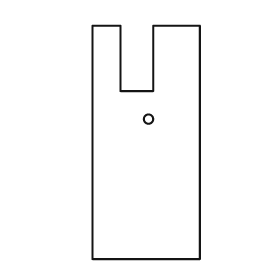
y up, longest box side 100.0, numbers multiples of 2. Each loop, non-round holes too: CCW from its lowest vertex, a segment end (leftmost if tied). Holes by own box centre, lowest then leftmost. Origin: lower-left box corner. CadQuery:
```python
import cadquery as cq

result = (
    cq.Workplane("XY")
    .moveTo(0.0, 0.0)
    .lineTo(46.0, 0.0)
    .lineTo(46.0, 100.0)
    .lineTo(26.0, 100.0)
    .lineTo(26.0, 72.0)
    .lineTo(12.0, 72.0)
    .lineTo(12.0, 100.0)
    .lineTo(0.0, 100.0)
    .close()
    .moveTo(24.0, 60.0)
    .circle(2.0)
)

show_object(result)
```